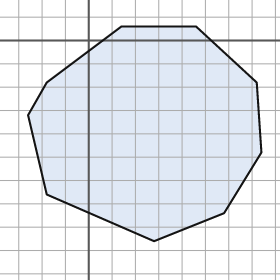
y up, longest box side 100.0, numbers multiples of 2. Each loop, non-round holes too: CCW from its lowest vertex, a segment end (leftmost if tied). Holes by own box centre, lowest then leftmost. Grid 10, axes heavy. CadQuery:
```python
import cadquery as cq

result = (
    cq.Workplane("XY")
    .moveTo(28.0, -86.0)
    .lineTo(58.0, -74.0)
    .lineTo(74.0, -48.0)
    .lineTo(72.0, -18.0)
    .lineTo(46.0, 6.0)
    .lineTo(14.0, 6.0)
    .lineTo(-18.0, -18.0)
    .lineTo(-26.0, -32.0)
    .lineTo(-18.0, -66.0)
    .close()
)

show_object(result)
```